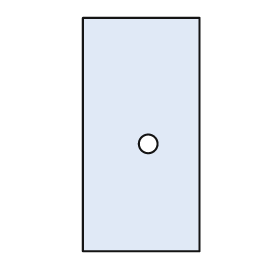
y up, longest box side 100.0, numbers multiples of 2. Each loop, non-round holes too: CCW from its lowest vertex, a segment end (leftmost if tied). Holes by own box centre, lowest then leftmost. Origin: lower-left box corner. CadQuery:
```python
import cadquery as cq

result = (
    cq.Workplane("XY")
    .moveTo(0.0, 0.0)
    .lineTo(50.0, 0.0)
    .lineTo(50.0, 100.0)
    .lineTo(0.0, 100.0)
    .close()
    .moveTo(28.0, 46.0)
    .circle(4.0)
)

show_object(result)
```